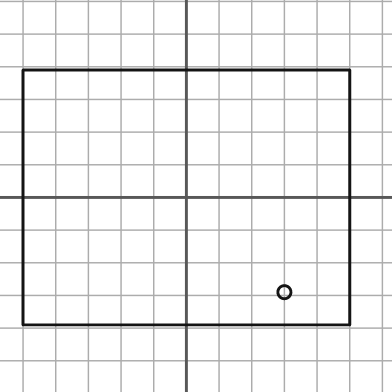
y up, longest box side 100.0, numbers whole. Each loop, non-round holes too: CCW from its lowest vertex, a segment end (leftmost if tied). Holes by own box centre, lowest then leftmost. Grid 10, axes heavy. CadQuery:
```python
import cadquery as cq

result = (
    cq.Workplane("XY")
    .moveTo(-50.0, -39.0)
    .lineTo(50.0, -39.0)
    .lineTo(50.0, 39.0)
    .lineTo(-50.0, 39.0)
    .close()
    .moveTo(30.0, -29.0)
    .circle(2.0)
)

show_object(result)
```